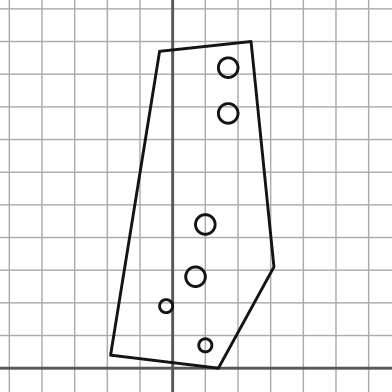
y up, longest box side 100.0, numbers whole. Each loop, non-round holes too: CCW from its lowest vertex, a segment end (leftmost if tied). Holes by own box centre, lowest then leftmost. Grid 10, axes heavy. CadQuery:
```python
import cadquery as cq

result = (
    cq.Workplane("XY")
    .moveTo(14.0, 0.0)
    .lineTo(31.0, 31.0)
    .lineTo(24.0, 100.0)
    .lineTo(-4.0, 97.0)
    .lineTo(-19.0, 4.0)
    .close()
    .moveTo(10.0, 7.0)
    .circle(2.0)
    .moveTo(-2.0, 19.0)
    .circle(2.0)
    .moveTo(7.0, 28.0)
    .circle(3.0)
    .moveTo(10.0, 44.0)
    .circle(3.0)
    .moveTo(17.0, 78.0)
    .circle(3.0)
    .moveTo(17.0, 92.0)
    .circle(3.0)
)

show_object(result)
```